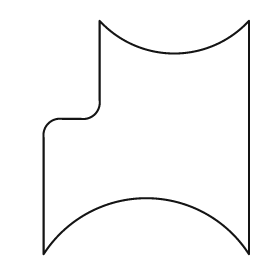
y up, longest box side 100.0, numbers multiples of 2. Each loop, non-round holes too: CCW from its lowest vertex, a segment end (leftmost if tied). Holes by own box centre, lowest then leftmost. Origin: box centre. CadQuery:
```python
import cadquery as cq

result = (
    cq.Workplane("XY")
    .moveTo(-44.0, -50.0)
    .threePointArc((0.0, -26.0), (44.0, -50.0))
    .lineTo(44.0, 50.0)
    .threePointArc((12.0, 36.0), (-20.0, 50.0))
    .lineTo(-20.0, 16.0)
    .threePointArc((-22.0, 10.0), (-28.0, 8.0))
    .lineTo(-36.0, 8.0)
    .threePointArc((-42.0, 6.0), (-44.0, 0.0))
    .close()
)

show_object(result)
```